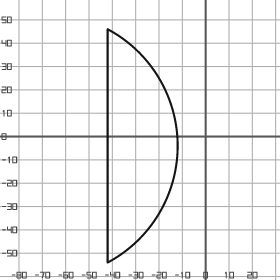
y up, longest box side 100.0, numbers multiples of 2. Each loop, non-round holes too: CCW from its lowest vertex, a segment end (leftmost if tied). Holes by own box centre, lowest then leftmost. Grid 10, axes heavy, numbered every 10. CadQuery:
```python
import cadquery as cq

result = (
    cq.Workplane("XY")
    .moveTo(-42.0, -54.0)
    .threePointArc((-12.0, -4.0), (-42.0, 46.0))
    .close()
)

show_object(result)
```